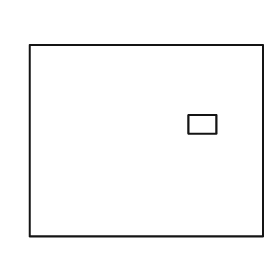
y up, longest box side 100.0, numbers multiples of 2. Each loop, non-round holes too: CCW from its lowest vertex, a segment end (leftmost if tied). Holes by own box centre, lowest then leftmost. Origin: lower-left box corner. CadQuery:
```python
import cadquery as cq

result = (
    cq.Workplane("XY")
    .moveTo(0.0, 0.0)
    .lineTo(100.0, 0.0)
    .lineTo(100.0, 82.0)
    .lineTo(0.0, 82.0)
    .close()
    .moveTo(68.0, 44.0)
    .lineTo(80.0, 44.0)
    .lineTo(80.0, 52.0)
    .lineTo(68.0, 52.0)
    .close()
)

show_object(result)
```